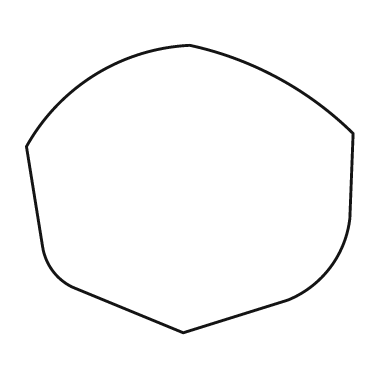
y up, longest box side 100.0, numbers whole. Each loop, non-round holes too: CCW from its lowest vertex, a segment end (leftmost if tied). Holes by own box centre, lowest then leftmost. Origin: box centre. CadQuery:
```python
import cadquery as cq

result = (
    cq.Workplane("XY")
    .moveTo(-2.0, -44.0)
    .lineTo(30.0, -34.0)
    .threePointArc((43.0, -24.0), (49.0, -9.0))
    .lineTo(50.0, 17.0)
    .threePointArc((27.0, 34.0), (0.0, 44.0))
    .threePointArc((-29.0, 35.0), (-50.0, 13.0))
    .lineTo(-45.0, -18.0)
    .threePointArc((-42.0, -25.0), (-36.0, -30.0))
    .close()
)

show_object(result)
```